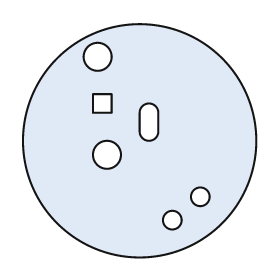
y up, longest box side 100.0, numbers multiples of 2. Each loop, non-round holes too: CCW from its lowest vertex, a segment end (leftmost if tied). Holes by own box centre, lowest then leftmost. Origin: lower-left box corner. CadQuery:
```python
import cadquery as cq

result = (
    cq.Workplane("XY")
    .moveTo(50.0, 50.0)
    .circle(50.0)
    .moveTo(64.0, 16.0)
    .circle(4.0)
    .moveTo(76.0, 26.0)
    .circle(4.0)
    .moveTo(36.0, 44.0)
    .circle(6.0)
    .moveTo(50.0, 54.0)
    .threePointArc((54.0, 50.0), (58.0, 54.0))
    .lineTo(58.0, 62.0)
    .threePointArc((54.0, 66.0), (50.0, 62.0))
    .close()
    .moveTo(30.0, 62.0)
    .lineTo(38.0, 62.0)
    .lineTo(38.0, 70.0)
    .lineTo(30.0, 70.0)
    .close()
    .moveTo(32.0, 86.0)
    .circle(6.0)
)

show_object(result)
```